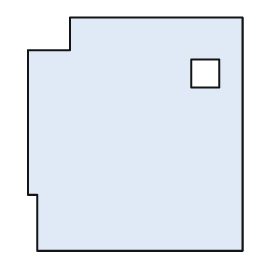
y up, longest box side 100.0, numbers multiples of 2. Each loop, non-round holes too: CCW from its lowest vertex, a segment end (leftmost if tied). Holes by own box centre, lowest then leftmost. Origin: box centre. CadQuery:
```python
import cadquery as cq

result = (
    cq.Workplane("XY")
    .moveTo(-42.0, -50.0)
    .lineTo(46.0, -50.0)
    .lineTo(46.0, 50.0)
    .lineTo(-28.0, 50.0)
    .lineTo(-28.0, 36.0)
    .lineTo(-46.0, 36.0)
    .lineTo(-46.0, -26.0)
    .lineTo(-42.0, -26.0)
    .close()
    .moveTo(24.0, 20.0)
    .lineTo(36.0, 20.0)
    .lineTo(36.0, 32.0)
    .lineTo(24.0, 32.0)
    .close()
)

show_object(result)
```